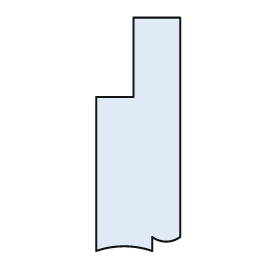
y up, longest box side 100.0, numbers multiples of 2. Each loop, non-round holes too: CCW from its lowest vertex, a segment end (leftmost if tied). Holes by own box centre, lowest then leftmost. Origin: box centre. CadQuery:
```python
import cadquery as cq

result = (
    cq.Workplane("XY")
    .moveTo(-18.0, -50.0)
    .threePointArc((-6.0, -48.0), (6.0, -50.0))
    .lineTo(6.0, -44.0)
    .threePointArc((12.0, -46.0), (18.0, -44.0))
    .lineTo(18.0, 50.0)
    .lineTo(-2.0, 50.0)
    .lineTo(-2.0, 16.0)
    .lineTo(-18.0, 16.0)
    .close()
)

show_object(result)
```